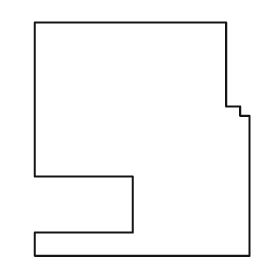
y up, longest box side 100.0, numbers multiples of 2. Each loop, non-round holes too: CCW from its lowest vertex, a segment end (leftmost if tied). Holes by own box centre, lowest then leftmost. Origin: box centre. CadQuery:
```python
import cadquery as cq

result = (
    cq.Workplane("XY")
    .moveTo(-46.0, -50.0)
    .lineTo(46.0, -50.0)
    .lineTo(46.0, 10.0)
    .lineTo(42.0, 10.0)
    .lineTo(42.0, 14.0)
    .lineTo(36.0, 14.0)
    .lineTo(36.0, 50.0)
    .lineTo(-46.0, 50.0)
    .lineTo(-46.0, -16.0)
    .lineTo(-4.0, -16.0)
    .lineTo(-4.0, -40.0)
    .lineTo(-46.0, -40.0)
    .close()
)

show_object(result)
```